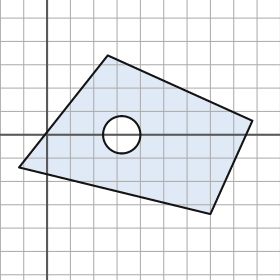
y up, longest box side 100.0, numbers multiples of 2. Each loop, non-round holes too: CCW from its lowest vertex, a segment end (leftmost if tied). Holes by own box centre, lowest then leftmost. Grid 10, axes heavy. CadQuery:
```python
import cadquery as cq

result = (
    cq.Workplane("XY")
    .moveTo(70.0, -34.0)
    .lineTo(88.0, 6.0)
    .lineTo(26.0, 34.0)
    .lineTo(-12.0, -14.0)
    .close()
    .moveTo(32.0, 0.0)
    .circle(8.0)
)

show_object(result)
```